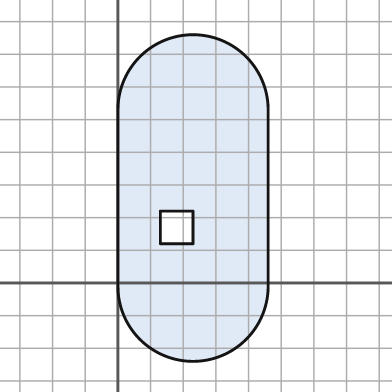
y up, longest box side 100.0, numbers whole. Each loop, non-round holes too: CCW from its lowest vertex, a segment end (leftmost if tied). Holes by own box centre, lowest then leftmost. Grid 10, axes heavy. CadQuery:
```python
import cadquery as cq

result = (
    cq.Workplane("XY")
    .moveTo(0.0, -1.0)
    .threePointArc((23.0, -24.0), (46.0, -1.0))
    .lineTo(46.0, 53.0)
    .threePointArc((23.0, 76.0), (0.0, 53.0))
    .close()
    .moveTo(13.0, 12.0)
    .lineTo(23.0, 12.0)
    .lineTo(23.0, 22.0)
    .lineTo(13.0, 22.0)
    .close()
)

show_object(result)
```